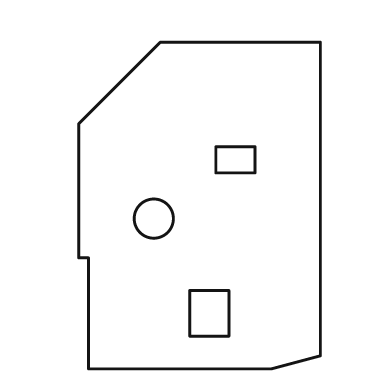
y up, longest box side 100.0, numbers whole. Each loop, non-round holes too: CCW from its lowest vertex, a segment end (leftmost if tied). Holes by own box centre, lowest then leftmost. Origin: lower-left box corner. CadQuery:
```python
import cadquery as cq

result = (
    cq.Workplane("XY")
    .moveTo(3.0, 0.0)
    .lineTo(59.0, 0.0)
    .lineTo(74.0, 4.0)
    .lineTo(74.0, 100.0)
    .lineTo(25.0, 100.0)
    .lineTo(0.0, 75.0)
    .lineTo(0.0, 34.0)
    .lineTo(3.0, 34.0)
    .close()
    .moveTo(34.0, 10.0)
    .lineTo(46.0, 10.0)
    .lineTo(46.0, 24.0)
    .lineTo(34.0, 24.0)
    .close()
    .moveTo(23.0, 46.0)
    .circle(6.0)
    .moveTo(42.0, 60.0)
    .lineTo(54.0, 60.0)
    .lineTo(54.0, 68.0)
    .lineTo(42.0, 68.0)
    .close()
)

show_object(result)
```